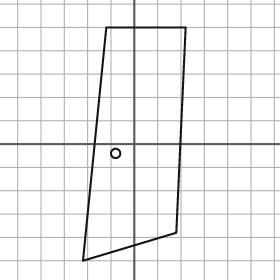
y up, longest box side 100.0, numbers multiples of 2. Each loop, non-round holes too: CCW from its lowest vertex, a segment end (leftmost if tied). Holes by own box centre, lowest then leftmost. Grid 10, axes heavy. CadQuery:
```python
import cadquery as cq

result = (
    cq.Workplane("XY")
    .moveTo(-22.0, -50.0)
    .lineTo(18.0, -38.0)
    .lineTo(22.0, 50.0)
    .lineTo(-12.0, 50.0)
    .close()
    .moveTo(-8.0, -4.0)
    .circle(2.0)
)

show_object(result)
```